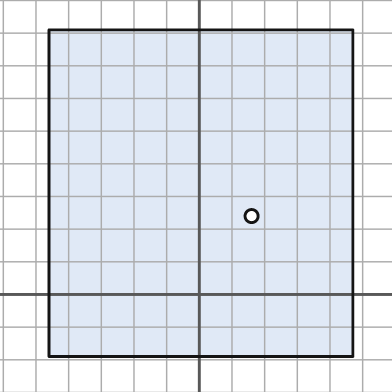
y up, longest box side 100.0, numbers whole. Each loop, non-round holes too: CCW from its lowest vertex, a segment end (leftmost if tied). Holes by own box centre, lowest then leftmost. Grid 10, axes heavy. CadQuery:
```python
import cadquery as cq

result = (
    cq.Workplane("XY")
    .moveTo(-46.0, -19.0)
    .lineTo(47.0, -19.0)
    .lineTo(47.0, 81.0)
    .lineTo(-46.0, 81.0)
    .close()
    .moveTo(16.0, 24.0)
    .circle(2.0)
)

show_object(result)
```